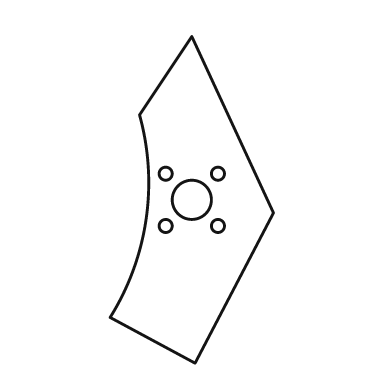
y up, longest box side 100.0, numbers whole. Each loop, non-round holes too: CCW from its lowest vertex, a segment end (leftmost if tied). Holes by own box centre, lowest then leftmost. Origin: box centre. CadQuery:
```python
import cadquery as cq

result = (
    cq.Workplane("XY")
    .moveTo(1.0, -50.0)
    .lineTo(25.0, -4.0)
    .lineTo(0.0, 50.0)
    .lineTo(-16.0, 26.0)
    .threePointArc((-14.0, -6.0), (-25.0, -36.0))
    .close()
    .moveTo(-8.0, -8.0)
    .circle(2.0)
    .moveTo(8.0, -8.0)
    .circle(2.0)
    .moveTo(0.0, 0.0)
    .circle(6.0)
    .moveTo(-8.0, 8.0)
    .circle(2.0)
    .moveTo(8.0, 8.0)
    .circle(2.0)
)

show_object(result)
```